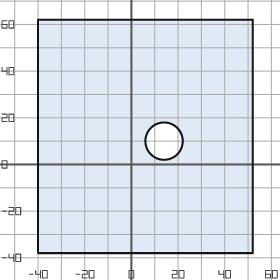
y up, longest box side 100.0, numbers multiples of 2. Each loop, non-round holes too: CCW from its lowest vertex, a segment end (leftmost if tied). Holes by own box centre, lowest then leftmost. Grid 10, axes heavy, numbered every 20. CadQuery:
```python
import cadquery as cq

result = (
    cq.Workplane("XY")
    .moveTo(-40.0, -38.0)
    .lineTo(52.0, -38.0)
    .lineTo(52.0, 62.0)
    .lineTo(-40.0, 62.0)
    .close()
    .moveTo(14.0, 10.0)
    .circle(8.0)
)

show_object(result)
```